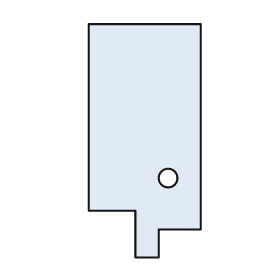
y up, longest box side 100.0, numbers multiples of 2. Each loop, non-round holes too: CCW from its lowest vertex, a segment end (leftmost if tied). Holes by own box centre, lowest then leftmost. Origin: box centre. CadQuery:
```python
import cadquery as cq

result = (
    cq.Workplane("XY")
    .moveTo(-4.0, -50.0)
    .lineTo(6.0, -50.0)
    .lineTo(6.0, -38.0)
    .lineTo(24.0, -38.0)
    .lineTo(24.0, 50.0)
    .lineTo(-24.0, 50.0)
    .lineTo(-24.0, -30.0)
    .lineTo(-4.0, -30.0)
    .close()
    .moveTo(10.0, -16.0)
    .circle(4.0)
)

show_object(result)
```